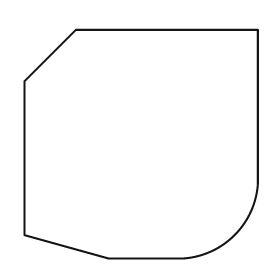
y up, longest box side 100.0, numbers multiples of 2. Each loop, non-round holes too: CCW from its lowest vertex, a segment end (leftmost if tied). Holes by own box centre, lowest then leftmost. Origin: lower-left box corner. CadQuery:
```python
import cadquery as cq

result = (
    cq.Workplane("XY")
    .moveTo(36.0, 0.0)
    .lineTo(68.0, 0.0)
    .threePointArc((90.0, 10.0), (100.0, 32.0))
    .lineTo(100.0, 98.0)
    .lineTo(22.0, 98.0)
    .lineTo(0.0, 76.0)
    .lineTo(0.0, 10.0)
    .close()
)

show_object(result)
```